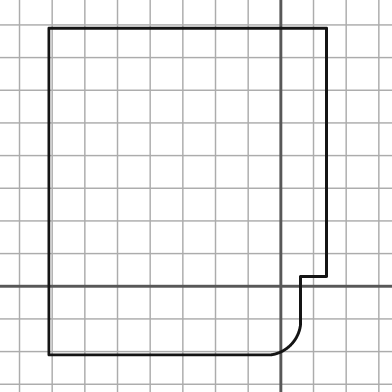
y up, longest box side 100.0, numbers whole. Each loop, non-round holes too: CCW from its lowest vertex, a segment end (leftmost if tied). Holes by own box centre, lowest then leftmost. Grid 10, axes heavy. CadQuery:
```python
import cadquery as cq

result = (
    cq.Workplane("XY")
    .moveTo(-71.0, -21.0)
    .lineTo(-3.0, -21.0)
    .threePointArc((3.0, -18.0), (6.0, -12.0))
    .lineTo(6.0, 3.0)
    .lineTo(14.0, 3.0)
    .lineTo(14.0, 79.0)
    .lineTo(-71.0, 79.0)
    .close()
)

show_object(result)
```